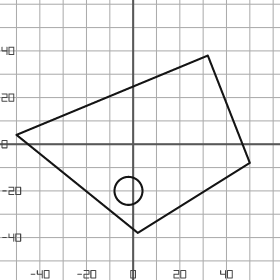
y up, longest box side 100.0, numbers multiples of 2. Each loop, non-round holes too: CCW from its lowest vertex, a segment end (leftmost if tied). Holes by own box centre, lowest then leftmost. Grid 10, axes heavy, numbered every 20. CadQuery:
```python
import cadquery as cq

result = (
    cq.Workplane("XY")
    .moveTo(2.0, -38.0)
    .lineTo(50.0, -8.0)
    .lineTo(32.0, 38.0)
    .lineTo(-50.0, 4.0)
    .close()
    .moveTo(-2.0, -20.0)
    .circle(6.0)
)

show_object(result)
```